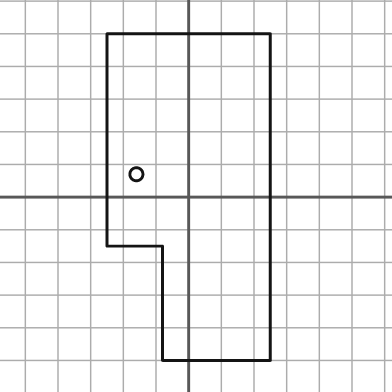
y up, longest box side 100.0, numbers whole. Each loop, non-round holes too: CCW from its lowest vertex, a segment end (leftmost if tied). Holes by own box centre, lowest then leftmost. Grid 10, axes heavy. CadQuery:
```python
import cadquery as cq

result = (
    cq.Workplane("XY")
    .moveTo(-8.0, -50.0)
    .lineTo(25.0, -50.0)
    .lineTo(25.0, 50.0)
    .lineTo(-25.0, 50.0)
    .lineTo(-25.0, -15.0)
    .lineTo(-8.0, -15.0)
    .close()
    .moveTo(-16.0, 7.0)
    .circle(2.0)
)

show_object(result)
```